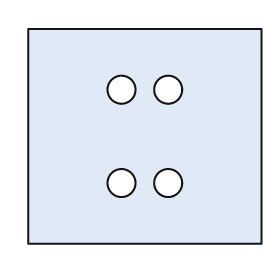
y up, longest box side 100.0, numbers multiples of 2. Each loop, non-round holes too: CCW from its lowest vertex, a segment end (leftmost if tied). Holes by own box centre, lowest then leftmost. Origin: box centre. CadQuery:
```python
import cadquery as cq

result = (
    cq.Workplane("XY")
    .moveTo(-50.0, -46.0)
    .lineTo(50.0, -46.0)
    .lineTo(50.0, 46.0)
    .lineTo(-50.0, 46.0)
    .close()
    .moveTo(-10.0, -20.0)
    .circle(6.0)
    .moveTo(10.0, -20.0)
    .circle(6.0)
    .moveTo(-10.0, 20.0)
    .circle(6.0)
    .moveTo(10.0, 20.0)
    .circle(6.0)
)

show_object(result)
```